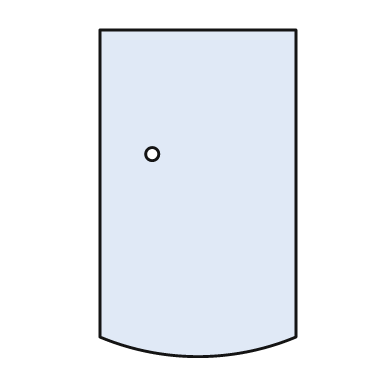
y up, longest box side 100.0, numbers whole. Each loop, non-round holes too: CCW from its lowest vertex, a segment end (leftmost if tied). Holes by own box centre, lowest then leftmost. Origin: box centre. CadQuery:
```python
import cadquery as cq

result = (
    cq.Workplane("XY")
    .moveTo(-30.0, -44.0)
    .threePointArc((0.0, -50.0), (30.0, -44.0))
    .lineTo(30.0, 50.0)
    .lineTo(-30.0, 50.0)
    .close()
    .moveTo(-14.0, 12.0)
    .circle(2.0)
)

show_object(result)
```